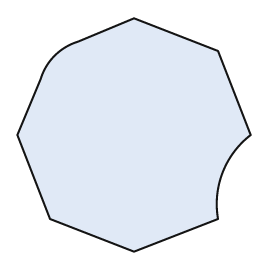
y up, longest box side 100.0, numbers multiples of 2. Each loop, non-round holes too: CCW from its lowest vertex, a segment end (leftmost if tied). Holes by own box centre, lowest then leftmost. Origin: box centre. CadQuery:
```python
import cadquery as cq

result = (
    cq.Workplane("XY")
    .moveTo(0.0, -50.0)
    .lineTo(36.0, -36.0)
    .threePointArc((38.0, -16.0), (50.0, 0.0))
    .lineTo(36.0, 36.0)
    .lineTo(0.0, 50.0)
    .lineTo(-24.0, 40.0)
    .threePointArc((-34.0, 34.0), (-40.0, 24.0))
    .lineTo(-50.0, 0.0)
    .lineTo(-36.0, -36.0)
    .close()
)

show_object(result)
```